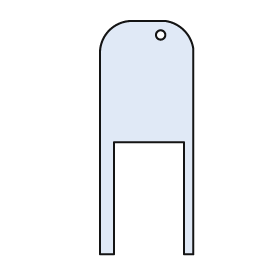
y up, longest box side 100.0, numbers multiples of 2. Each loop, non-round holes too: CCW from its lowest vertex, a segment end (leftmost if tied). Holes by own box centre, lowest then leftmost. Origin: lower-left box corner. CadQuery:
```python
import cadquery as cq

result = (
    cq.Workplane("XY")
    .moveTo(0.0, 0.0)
    .lineTo(6.0, 0.0)
    .lineTo(6.0, 48.0)
    .lineTo(36.0, 48.0)
    .lineTo(36.0, 0.0)
    .lineTo(40.0, 0.0)
    .lineTo(40.0, 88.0)
    .threePointArc((36.0, 96.0), (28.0, 100.0))
    .lineTo(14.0, 100.0)
    .threePointArc((4.0, 96.0), (0.0, 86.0))
    .close()
    .moveTo(26.0, 94.0)
    .circle(2.0)
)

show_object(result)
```